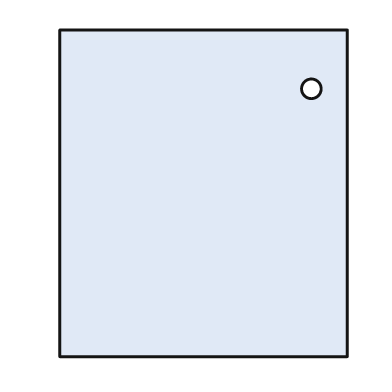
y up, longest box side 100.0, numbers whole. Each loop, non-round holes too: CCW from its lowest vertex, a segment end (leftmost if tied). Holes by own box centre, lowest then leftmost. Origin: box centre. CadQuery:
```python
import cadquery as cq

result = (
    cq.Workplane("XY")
    .moveTo(-44.0, -50.0)
    .lineTo(44.0, -50.0)
    .lineTo(44.0, 50.0)
    .lineTo(-44.0, 50.0)
    .close()
    .moveTo(33.0, 32.0)
    .circle(3.0)
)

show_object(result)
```